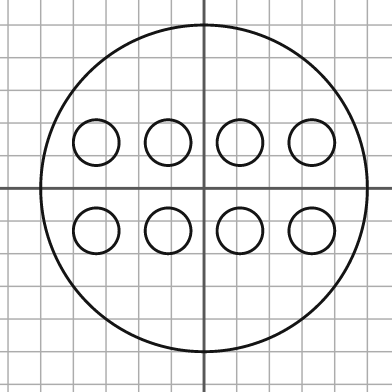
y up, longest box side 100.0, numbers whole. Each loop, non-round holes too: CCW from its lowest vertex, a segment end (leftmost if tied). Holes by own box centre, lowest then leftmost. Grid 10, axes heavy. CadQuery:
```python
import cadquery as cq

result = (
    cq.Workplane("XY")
    .moveTo(0.0, 0.0)
    .circle(50.0)
    .moveTo(-33.0, -13.0)
    .circle(7.0)
    .moveTo(-11.0, -13.0)
    .circle(7.0)
    .moveTo(11.0, -13.0)
    .circle(7.0)
    .moveTo(33.0, -13.0)
    .circle(7.0)
    .moveTo(-33.0, 14.0)
    .circle(7.0)
    .moveTo(-11.0, 14.0)
    .circle(7.0)
    .moveTo(11.0, 14.0)
    .circle(7.0)
    .moveTo(33.0, 14.0)
    .circle(7.0)
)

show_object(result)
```